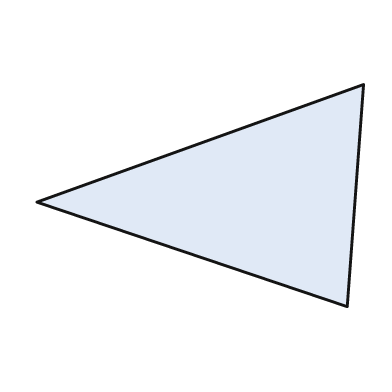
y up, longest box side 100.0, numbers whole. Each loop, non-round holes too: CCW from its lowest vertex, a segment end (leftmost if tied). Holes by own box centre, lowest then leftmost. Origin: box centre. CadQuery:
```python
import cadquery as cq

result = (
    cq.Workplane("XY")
    .moveTo(45.0, -34.0)
    .lineTo(50.0, 34.0)
    .lineTo(-50.0, -2.0)
    .close()
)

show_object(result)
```